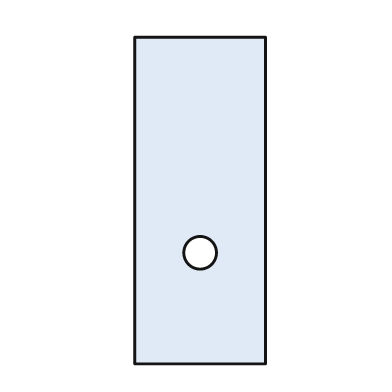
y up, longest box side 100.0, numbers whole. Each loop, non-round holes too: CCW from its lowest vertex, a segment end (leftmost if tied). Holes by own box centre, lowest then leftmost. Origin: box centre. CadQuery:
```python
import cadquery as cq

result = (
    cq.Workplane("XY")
    .moveTo(-20.0, -50.0)
    .lineTo(20.0, -50.0)
    .lineTo(20.0, 50.0)
    .lineTo(-20.0, 50.0)
    .close()
    .moveTo(0.0, -16.0)
    .circle(5.0)
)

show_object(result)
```